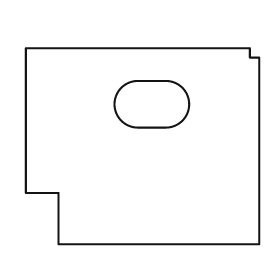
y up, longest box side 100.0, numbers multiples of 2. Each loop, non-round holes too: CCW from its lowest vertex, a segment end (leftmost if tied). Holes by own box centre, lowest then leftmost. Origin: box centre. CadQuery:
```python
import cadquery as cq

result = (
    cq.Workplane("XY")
    .moveTo(-36.0, -42.0)
    .lineTo(50.0, -42.0)
    .lineTo(50.0, 38.0)
    .lineTo(46.0, 38.0)
    .lineTo(46.0, 42.0)
    .lineTo(-50.0, 42.0)
    .lineTo(-50.0, -20.0)
    .lineTo(-36.0, -20.0)
    .close()
    .moveTo(-2.0, 8.0)
    .lineTo(10.0, 8.0)
    .threePointArc((20.0, 18.0), (10.0, 28.0))
    .lineTo(-2.0, 28.0)
    .threePointArc((-12.0, 18.0), (-2.0, 8.0))
    .close()
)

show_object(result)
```